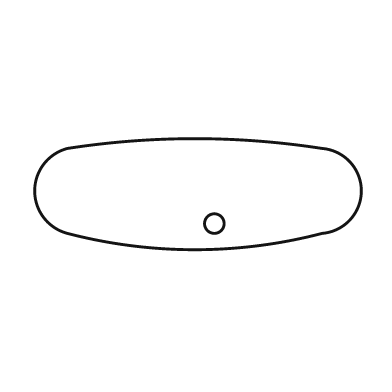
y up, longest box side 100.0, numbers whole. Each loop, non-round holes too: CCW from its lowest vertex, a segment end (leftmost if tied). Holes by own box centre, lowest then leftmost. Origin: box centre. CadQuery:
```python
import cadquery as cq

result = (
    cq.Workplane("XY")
    .moveTo(-40.0, -12.0)
    .threePointArc((-1.0, -17.0), (38.0, -12.0))
    .threePointArc((50.0, 1.0), (38.0, 14.0))
    .threePointArc((-1.0, 17.0), (-40.0, 14.0))
    .threePointArc((-50.0, 1.0), (-40.0, -12.0))
    .close()
    .moveTo(5.0, -9.0)
    .circle(3.0)
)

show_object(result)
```